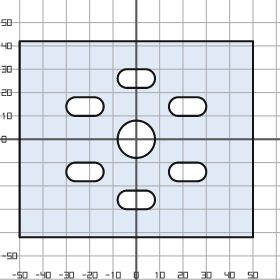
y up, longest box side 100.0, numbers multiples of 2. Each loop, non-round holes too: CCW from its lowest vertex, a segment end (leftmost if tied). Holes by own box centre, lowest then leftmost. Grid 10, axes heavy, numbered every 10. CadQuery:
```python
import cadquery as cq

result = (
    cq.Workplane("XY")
    .moveTo(-50.0, -42.0)
    .lineTo(50.0, -42.0)
    .lineTo(50.0, 42.0)
    .lineTo(-50.0, 42.0)
    .close()
    .moveTo(-4.0, -30.0)
    .lineTo(4.0, -30.0)
    .threePointArc((8.0, -26.0), (4.0, -22.0))
    .lineTo(-4.0, -22.0)
    .threePointArc((-8.0, -26.0), (-4.0, -30.0))
    .close()
    .moveTo(-26.0, -18.0)
    .lineTo(-18.0, -18.0)
    .threePointArc((-14.0, -14.0), (-18.0, -10.0))
    .lineTo(-26.0, -10.0)
    .threePointArc((-30.0, -14.0), (-26.0, -18.0))
    .close()
    .moveTo(18.0, -18.0)
    .lineTo(26.0, -18.0)
    .threePointArc((30.0, -14.0), (26.0, -10.0))
    .lineTo(18.0, -10.0)
    .threePointArc((14.0, -14.0), (18.0, -18.0))
    .close()
    .moveTo(0.0, 0.0)
    .circle(8.0)
    .moveTo(-26.0, 10.0)
    .lineTo(-18.0, 10.0)
    .threePointArc((-14.0, 14.0), (-18.0, 18.0))
    .lineTo(-26.0, 18.0)
    .threePointArc((-30.0, 14.0), (-26.0, 10.0))
    .close()
    .moveTo(18.0, 10.0)
    .lineTo(26.0, 10.0)
    .threePointArc((30.0, 14.0), (26.0, 18.0))
    .lineTo(18.0, 18.0)
    .threePointArc((14.0, 14.0), (18.0, 10.0))
    .close()
    .moveTo(-4.0, 22.0)
    .lineTo(4.0, 22.0)
    .threePointArc((8.0, 26.0), (4.0, 30.0))
    .lineTo(-4.0, 30.0)
    .threePointArc((-8.0, 26.0), (-4.0, 22.0))
    .close()
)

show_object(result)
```